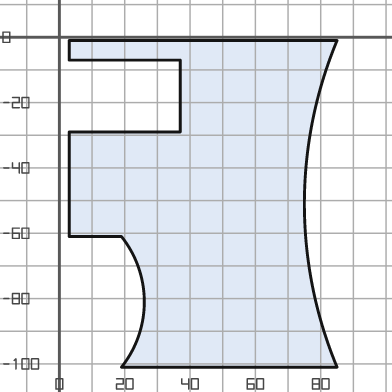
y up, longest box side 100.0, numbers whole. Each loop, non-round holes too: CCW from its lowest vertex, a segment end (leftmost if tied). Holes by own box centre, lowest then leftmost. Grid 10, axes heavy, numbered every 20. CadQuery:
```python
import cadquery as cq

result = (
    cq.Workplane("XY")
    .moveTo(19.0, -101.0)
    .lineTo(85.0, -101.0)
    .threePointArc((75.0, -51.0), (85.0, -1.0))
    .lineTo(3.0, -1.0)
    .lineTo(3.0, -7.0)
    .lineTo(37.0, -7.0)
    .lineTo(37.0, -29.0)
    .lineTo(3.0, -29.0)
    .lineTo(3.0, -61.0)
    .lineTo(19.0, -61.0)
    .threePointArc((26.0, -81.0), (19.0, -101.0))
    .close()
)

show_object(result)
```